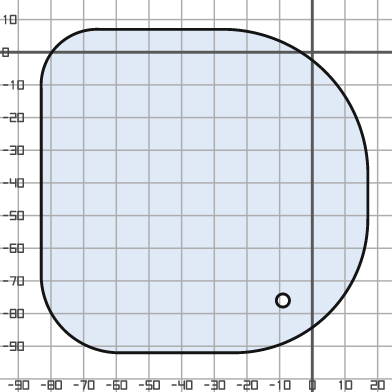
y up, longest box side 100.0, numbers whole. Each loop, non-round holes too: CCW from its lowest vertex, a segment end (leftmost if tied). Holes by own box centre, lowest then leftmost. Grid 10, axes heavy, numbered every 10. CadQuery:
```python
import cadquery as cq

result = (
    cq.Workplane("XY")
    .moveTo(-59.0, -92.0)
    .lineTo(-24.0, -92.0)
    .threePointArc((5.0, -80.0), (17.0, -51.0))
    .lineTo(17.0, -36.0)
    .threePointArc((4.0, -6.0), (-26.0, 7.0))
    .lineTo(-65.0, 7.0)
    .threePointArc((-78.0, 2.0), (-83.0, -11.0))
    .lineTo(-83.0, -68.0)
    .threePointArc((-76.0, -85.0), (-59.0, -92.0))
    .close()
    .moveTo(-9.0, -76.0)
    .circle(2.0)
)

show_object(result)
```